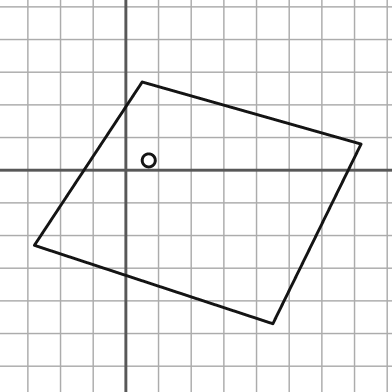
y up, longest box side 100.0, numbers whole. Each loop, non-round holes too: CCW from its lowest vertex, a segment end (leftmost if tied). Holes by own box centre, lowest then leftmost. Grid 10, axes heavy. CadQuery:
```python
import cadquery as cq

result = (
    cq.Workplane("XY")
    .moveTo(45.0, -47.0)
    .lineTo(72.0, 8.0)
    .lineTo(5.0, 27.0)
    .lineTo(-28.0, -23.0)
    .close()
    .moveTo(7.0, 3.0)
    .circle(2.0)
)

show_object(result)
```